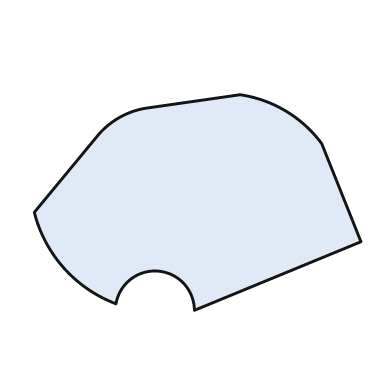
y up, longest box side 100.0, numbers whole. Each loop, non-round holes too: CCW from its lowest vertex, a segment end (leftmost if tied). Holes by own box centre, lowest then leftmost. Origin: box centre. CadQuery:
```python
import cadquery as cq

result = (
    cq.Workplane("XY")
    .moveTo(-1.0, -33.0)
    .lineTo(50.0, -12.0)
    .lineTo(38.0, 18.0)
    .threePointArc((27.0, 28.0), (13.0, 33.0))
    .lineTo(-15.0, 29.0)
    .threePointArc((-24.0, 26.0), (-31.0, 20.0))
    .lineTo(-50.0, -3.0)
    .threePointArc((-41.0, -20.0), (-25.0, -31.0))
    .threePointArc((-12.0, -21.0), (-1.0, -33.0))
    .close()
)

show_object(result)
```